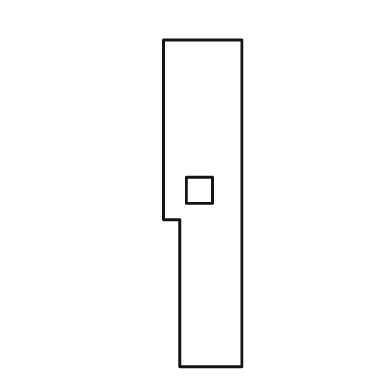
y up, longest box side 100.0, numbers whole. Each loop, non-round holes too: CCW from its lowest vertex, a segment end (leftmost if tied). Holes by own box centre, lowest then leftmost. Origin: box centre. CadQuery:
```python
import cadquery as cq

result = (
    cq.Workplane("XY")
    .moveTo(-7.0, -50.0)
    .lineTo(12.0, -50.0)
    .lineTo(12.0, 50.0)
    .lineTo(-12.0, 50.0)
    .lineTo(-12.0, -5.0)
    .lineTo(-7.0, -5.0)
    .close()
    .moveTo(-5.0, 0.0)
    .lineTo(3.0, 0.0)
    .lineTo(3.0, 8.0)
    .lineTo(-5.0, 8.0)
    .close()
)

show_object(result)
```